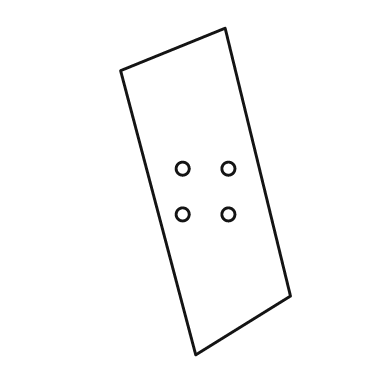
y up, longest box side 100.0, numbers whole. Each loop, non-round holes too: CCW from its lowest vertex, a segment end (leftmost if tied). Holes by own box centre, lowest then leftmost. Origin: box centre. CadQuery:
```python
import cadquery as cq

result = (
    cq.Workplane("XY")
    .moveTo(-3.0, -50.0)
    .lineTo(26.0, -32.0)
    .lineTo(6.0, 50.0)
    .lineTo(-26.0, 37.0)
    .close()
    .moveTo(-7.0, -7.0)
    .circle(2.0)
    .moveTo(7.0, -7.0)
    .circle(2.0)
    .moveTo(-7.0, 7.0)
    .circle(2.0)
    .moveTo(7.0, 7.0)
    .circle(2.0)
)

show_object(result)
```